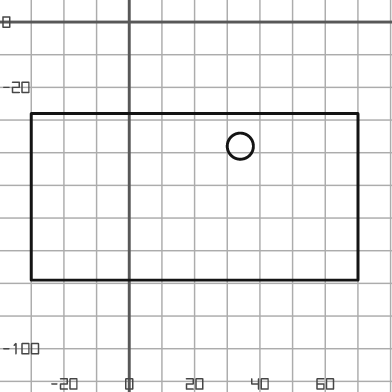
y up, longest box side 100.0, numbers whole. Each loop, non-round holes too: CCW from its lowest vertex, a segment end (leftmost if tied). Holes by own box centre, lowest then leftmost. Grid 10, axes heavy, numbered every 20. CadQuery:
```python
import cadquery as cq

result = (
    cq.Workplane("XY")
    .moveTo(-30.0, -79.0)
    .lineTo(70.0, -79.0)
    .lineTo(70.0, -28.0)
    .lineTo(-30.0, -28.0)
    .close()
    .moveTo(34.0, -38.0)
    .circle(4.0)
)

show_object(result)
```